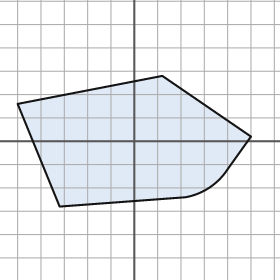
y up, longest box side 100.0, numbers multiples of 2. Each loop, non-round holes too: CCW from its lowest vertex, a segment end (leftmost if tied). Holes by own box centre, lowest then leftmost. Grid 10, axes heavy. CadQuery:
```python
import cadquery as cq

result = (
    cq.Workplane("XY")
    .moveTo(-32.0, -28.0)
    .lineTo(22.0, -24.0)
    .threePointArc((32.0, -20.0), (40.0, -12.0))
    .lineTo(50.0, 2.0)
    .lineTo(12.0, 28.0)
    .lineTo(-50.0, 16.0)
    .close()
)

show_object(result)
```